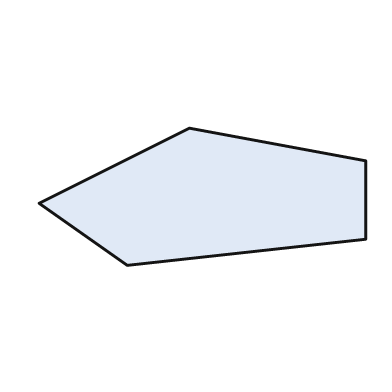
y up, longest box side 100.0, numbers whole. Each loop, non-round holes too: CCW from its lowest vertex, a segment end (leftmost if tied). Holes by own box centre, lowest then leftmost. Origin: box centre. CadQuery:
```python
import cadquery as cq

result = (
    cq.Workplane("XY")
    .moveTo(-23.0, -21.0)
    .lineTo(50.0, -13.0)
    .lineTo(50.0, 11.0)
    .lineTo(-4.0, 21.0)
    .lineTo(-50.0, -2.0)
    .close()
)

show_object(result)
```